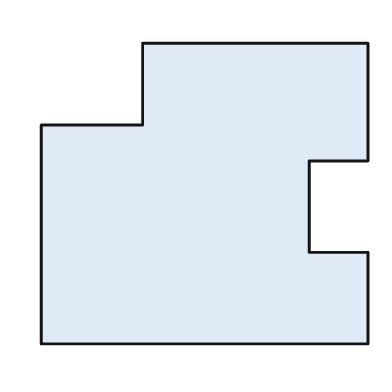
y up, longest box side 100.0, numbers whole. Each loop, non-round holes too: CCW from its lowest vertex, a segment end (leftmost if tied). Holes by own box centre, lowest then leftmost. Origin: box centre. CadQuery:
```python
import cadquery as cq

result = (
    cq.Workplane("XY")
    .moveTo(-50.0, -46.0)
    .lineTo(50.0, -46.0)
    .lineTo(50.0, -18.0)
    .lineTo(32.0, -18.0)
    .lineTo(32.0, 10.0)
    .lineTo(50.0, 10.0)
    .lineTo(50.0, 46.0)
    .lineTo(-19.0, 46.0)
    .lineTo(-19.0, 21.0)
    .lineTo(-50.0, 21.0)
    .close()
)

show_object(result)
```